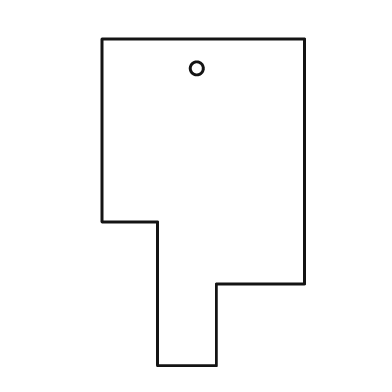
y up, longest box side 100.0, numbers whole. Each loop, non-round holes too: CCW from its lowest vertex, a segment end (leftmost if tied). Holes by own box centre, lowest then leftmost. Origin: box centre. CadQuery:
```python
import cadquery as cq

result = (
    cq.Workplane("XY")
    .moveTo(-14.0, -50.0)
    .lineTo(4.0, -50.0)
    .lineTo(4.0, -25.0)
    .lineTo(31.0, -25.0)
    .lineTo(31.0, 50.0)
    .lineTo(-31.0, 50.0)
    .lineTo(-31.0, -6.0)
    .lineTo(-14.0, -6.0)
    .close()
    .moveTo(-2.0, 41.0)
    .circle(2.0)
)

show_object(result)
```